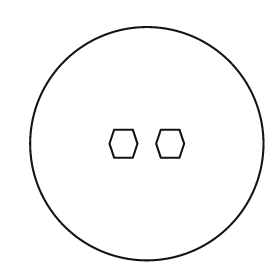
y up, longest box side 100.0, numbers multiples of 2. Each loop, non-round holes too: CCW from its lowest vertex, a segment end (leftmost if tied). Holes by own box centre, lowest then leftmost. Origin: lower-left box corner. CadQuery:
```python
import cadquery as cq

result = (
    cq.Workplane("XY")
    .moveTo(50.0, 50.0)
    .circle(50.0)
    .moveTo(36.0, 44.0)
    .lineTo(44.0, 44.0)
    .lineTo(46.0, 50.0)
    .lineTo(44.0, 56.0)
    .lineTo(36.0, 56.0)
    .lineTo(34.0, 50.0)
    .close()
    .moveTo(56.0, 44.0)
    .lineTo(64.0, 44.0)
    .lineTo(66.0, 50.0)
    .lineTo(64.0, 56.0)
    .lineTo(56.0, 56.0)
    .lineTo(54.0, 50.0)
    .close()
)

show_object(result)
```